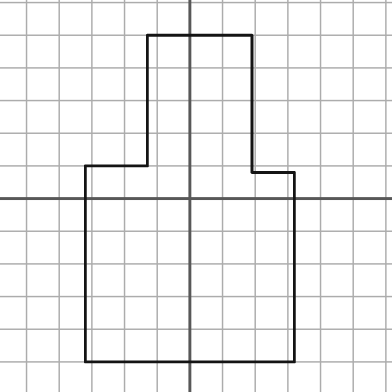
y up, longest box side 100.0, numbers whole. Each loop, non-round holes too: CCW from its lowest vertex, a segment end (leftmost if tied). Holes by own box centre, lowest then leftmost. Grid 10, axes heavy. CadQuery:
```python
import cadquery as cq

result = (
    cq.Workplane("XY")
    .moveTo(-32.0, -50.0)
    .lineTo(32.0, -50.0)
    .lineTo(32.0, 8.0)
    .lineTo(19.0, 8.0)
    .lineTo(19.0, 50.0)
    .lineTo(-13.0, 50.0)
    .lineTo(-13.0, 10.0)
    .lineTo(-32.0, 10.0)
    .close()
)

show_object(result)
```